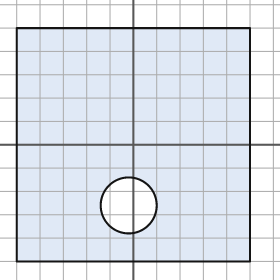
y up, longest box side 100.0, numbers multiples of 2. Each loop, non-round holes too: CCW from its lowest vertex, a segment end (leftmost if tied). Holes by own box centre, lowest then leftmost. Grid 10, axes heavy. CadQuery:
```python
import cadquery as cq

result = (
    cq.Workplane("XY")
    .moveTo(-50.0, -50.0)
    .lineTo(50.0, -50.0)
    .lineTo(50.0, 50.0)
    .lineTo(-50.0, 50.0)
    .close()
    .moveTo(-2.0, -26.0)
    .circle(12.0)
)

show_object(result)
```